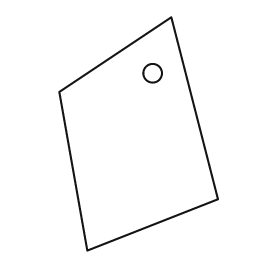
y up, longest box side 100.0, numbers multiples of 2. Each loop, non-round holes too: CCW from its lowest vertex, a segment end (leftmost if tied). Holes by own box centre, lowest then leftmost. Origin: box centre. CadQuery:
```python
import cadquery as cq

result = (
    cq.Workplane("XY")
    .moveTo(-22.0, -50.0)
    .lineTo(34.0, -28.0)
    .lineTo(14.0, 50.0)
    .lineTo(-34.0, 18.0)
    .close()
    .moveTo(6.0, 26.0)
    .circle(4.0)
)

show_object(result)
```